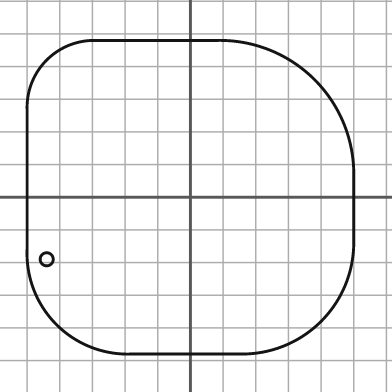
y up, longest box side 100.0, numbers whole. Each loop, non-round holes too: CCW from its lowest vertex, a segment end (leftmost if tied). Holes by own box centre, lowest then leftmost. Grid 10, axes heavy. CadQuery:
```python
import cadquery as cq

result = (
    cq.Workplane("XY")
    .moveTo(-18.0, -48.0)
    .lineTo(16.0, -48.0)
    .threePointArc((40.0, -38.0), (50.0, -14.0))
    .lineTo(50.0, 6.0)
    .threePointArc((38.0, 36.0), (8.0, 48.0))
    .lineTo(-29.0, 48.0)
    .threePointArc((-44.0, 42.0), (-50.0, 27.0))
    .lineTo(-50.0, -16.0)
    .threePointArc((-41.0, -39.0), (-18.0, -48.0))
    .close()
    .moveTo(-44.0, -19.0)
    .circle(2.0)
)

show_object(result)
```